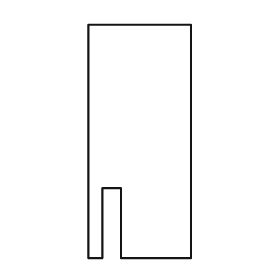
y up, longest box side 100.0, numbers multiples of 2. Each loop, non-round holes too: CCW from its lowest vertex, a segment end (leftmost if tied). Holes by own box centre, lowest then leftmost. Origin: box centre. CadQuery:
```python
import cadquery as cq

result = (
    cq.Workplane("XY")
    .moveTo(-22.0, -50.0)
    .lineTo(-16.0, -50.0)
    .lineTo(-16.0, -20.0)
    .lineTo(-8.0, -20.0)
    .lineTo(-8.0, -50.0)
    .lineTo(22.0, -50.0)
    .lineTo(22.0, 50.0)
    .lineTo(-22.0, 50.0)
    .close()
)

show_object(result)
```